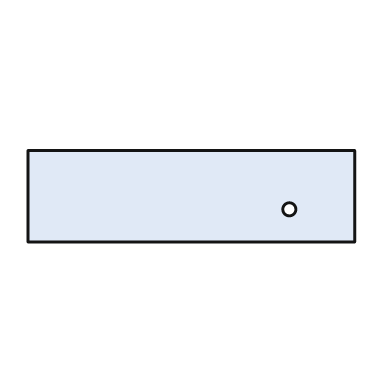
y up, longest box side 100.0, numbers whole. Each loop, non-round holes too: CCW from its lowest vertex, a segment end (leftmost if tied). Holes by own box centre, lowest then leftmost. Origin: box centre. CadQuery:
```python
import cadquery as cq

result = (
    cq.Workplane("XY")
    .moveTo(-50.0, -14.0)
    .lineTo(50.0, -14.0)
    .lineTo(50.0, 14.0)
    .lineTo(-50.0, 14.0)
    .close()
    .moveTo(30.0, -4.0)
    .circle(2.0)
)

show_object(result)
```